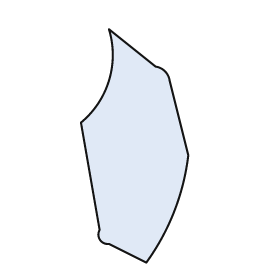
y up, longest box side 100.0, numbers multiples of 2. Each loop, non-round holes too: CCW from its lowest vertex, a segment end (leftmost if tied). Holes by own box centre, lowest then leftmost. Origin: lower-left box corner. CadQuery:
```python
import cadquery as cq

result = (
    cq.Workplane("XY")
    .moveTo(28.0, 0.0)
    .threePointArc((40.0, 22.0), (46.0, 46.0))
    .lineTo(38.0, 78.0)
    .threePointArc((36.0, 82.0), (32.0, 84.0))
    .lineTo(12.0, 100.0)
    .threePointArc((12.0, 78.0), (0.0, 60.0))
    .lineTo(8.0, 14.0)
    .threePointArc((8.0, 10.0), (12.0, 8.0))
    .close()
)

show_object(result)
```